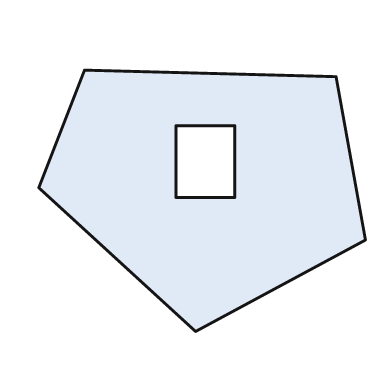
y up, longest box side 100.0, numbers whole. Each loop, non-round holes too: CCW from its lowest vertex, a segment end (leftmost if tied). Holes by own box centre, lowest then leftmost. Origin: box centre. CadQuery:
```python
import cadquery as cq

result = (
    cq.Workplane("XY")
    .moveTo(-2.0, -40.0)
    .lineTo(50.0, -12.0)
    .lineTo(41.0, 38.0)
    .lineTo(-36.0, 40.0)
    .lineTo(-50.0, 4.0)
    .close()
    .moveTo(-8.0, 1.0)
    .lineTo(10.0, 1.0)
    .lineTo(10.0, 23.0)
    .lineTo(-8.0, 23.0)
    .close()
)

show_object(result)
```